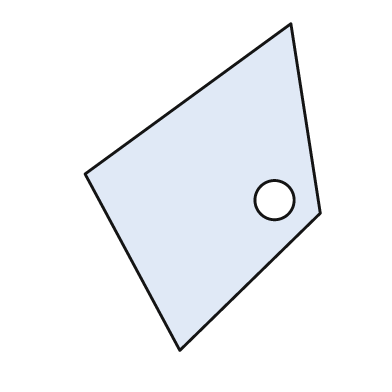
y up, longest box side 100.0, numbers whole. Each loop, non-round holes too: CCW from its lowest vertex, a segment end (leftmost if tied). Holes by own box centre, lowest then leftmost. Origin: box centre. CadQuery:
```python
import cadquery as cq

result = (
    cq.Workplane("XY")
    .moveTo(-7.0, -50.0)
    .lineTo(36.0, -8.0)
    .lineTo(27.0, 50.0)
    .lineTo(-36.0, 4.0)
    .close()
    .moveTo(22.0, -4.0)
    .circle(6.0)
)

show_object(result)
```